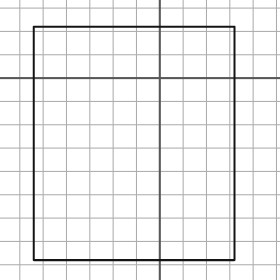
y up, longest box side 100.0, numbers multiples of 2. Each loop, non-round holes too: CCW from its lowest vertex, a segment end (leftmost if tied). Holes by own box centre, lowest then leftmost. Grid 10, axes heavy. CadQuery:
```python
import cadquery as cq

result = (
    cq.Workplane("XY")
    .moveTo(-54.0, -78.0)
    .lineTo(32.0, -78.0)
    .lineTo(32.0, 22.0)
    .lineTo(-54.0, 22.0)
    .close()
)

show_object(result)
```